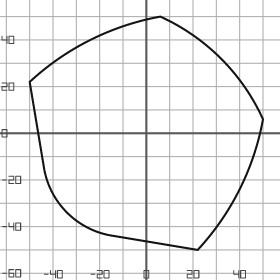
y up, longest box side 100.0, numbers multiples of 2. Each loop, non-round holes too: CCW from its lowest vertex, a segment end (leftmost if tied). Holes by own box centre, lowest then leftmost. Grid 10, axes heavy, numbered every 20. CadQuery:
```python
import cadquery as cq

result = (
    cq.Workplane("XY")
    .moveTo(22.0, -50.0)
    .threePointArc((40.0, -24.0), (50.0, 6.0))
    .threePointArc((32.0, 32.0), (6.0, 50.0))
    .threePointArc((-24.0, 40.0), (-50.0, 22.0))
    .lineTo(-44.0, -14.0)
    .threePointArc((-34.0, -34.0), (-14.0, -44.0))
    .close()
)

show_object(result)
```